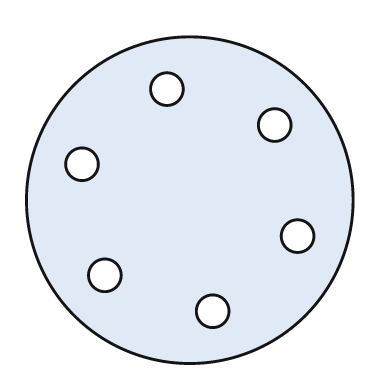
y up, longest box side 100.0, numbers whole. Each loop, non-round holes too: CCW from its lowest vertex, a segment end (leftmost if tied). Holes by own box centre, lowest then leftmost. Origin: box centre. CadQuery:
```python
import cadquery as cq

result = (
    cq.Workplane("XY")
    .moveTo(0.0, 0.0)
    .circle(50.0)
    .moveTo(7.0, -34.0)
    .circle(5.0)
    .moveTo(-26.0, -23.0)
    .circle(5.0)
    .moveTo(33.0, -11.0)
    .circle(5.0)
    .moveTo(-33.0, 11.0)
    .circle(5.0)
    .moveTo(26.0, 23.0)
    .circle(5.0)
    .moveTo(-7.0, 34.0)
    .circle(5.0)
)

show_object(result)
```